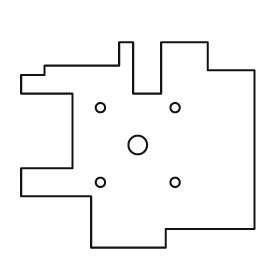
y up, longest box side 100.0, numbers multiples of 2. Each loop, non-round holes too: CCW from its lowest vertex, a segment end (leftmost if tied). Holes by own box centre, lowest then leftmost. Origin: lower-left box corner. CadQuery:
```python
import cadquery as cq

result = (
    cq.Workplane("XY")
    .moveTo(30.0, 0.0)
    .lineTo(62.0, 0.0)
    .lineTo(62.0, 8.0)
    .lineTo(100.0, 8.0)
    .lineTo(100.0, 76.0)
    .lineTo(80.0, 76.0)
    .lineTo(80.0, 88.0)
    .lineTo(60.0, 88.0)
    .lineTo(60.0, 66.0)
    .lineTo(48.0, 66.0)
    .lineTo(48.0, 88.0)
    .lineTo(42.0, 88.0)
    .lineTo(42.0, 78.0)
    .lineTo(10.0, 78.0)
    .lineTo(10.0, 74.0)
    .lineTo(0.0, 74.0)
    .lineTo(0.0, 66.0)
    .lineTo(22.0, 66.0)
    .lineTo(22.0, 34.0)
    .lineTo(0.0, 34.0)
    .lineTo(0.0, 22.0)
    .lineTo(30.0, 22.0)
    .close()
    .moveTo(34.0, 28.0)
    .circle(2.0)
    .moveTo(66.0, 28.0)
    .circle(2.0)
    .moveTo(50.0, 44.0)
    .circle(4.0)
    .moveTo(34.0, 60.0)
    .circle(2.0)
    .moveTo(66.0, 60.0)
    .circle(2.0)
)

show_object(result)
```